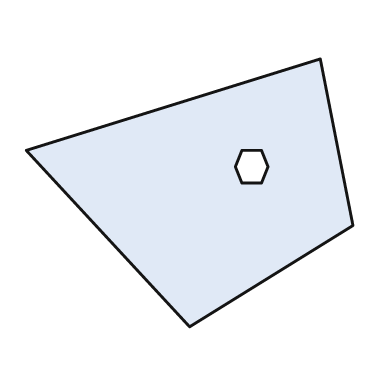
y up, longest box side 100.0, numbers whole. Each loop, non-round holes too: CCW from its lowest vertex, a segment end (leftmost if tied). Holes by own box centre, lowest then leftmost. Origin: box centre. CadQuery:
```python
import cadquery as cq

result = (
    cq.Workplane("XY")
    .moveTo(0.0, -41.0)
    .lineTo(50.0, -10.0)
    .lineTo(40.0, 41.0)
    .lineTo(-50.0, 13.0)
    .close()
    .moveTo(16.0, 3.0)
    .lineTo(22.0, 3.0)
    .lineTo(24.0, 8.0)
    .lineTo(22.0, 13.0)
    .lineTo(16.0, 13.0)
    .lineTo(14.0, 8.0)
    .close()
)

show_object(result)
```